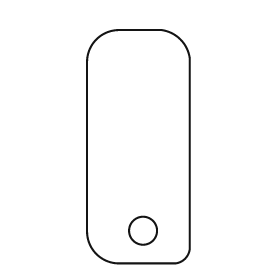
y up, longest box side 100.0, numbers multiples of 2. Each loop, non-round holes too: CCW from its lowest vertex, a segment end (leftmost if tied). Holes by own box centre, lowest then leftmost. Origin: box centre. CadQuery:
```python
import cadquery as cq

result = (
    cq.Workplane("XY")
    .moveTo(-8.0, -50.0)
    .lineTo(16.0, -50.0)
    .threePointArc((20.0, -48.0), (22.0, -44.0))
    .lineTo(22.0, 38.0)
    .threePointArc((18.0, 46.0), (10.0, 50.0))
    .lineTo(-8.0, 50.0)
    .threePointArc((-18.0, 46.0), (-22.0, 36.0))
    .lineTo(-22.0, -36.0)
    .threePointArc((-18.0, -46.0), (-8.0, -50.0))
    .close()
    .moveTo(2.0, -36.0)
    .circle(6.0)
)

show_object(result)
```